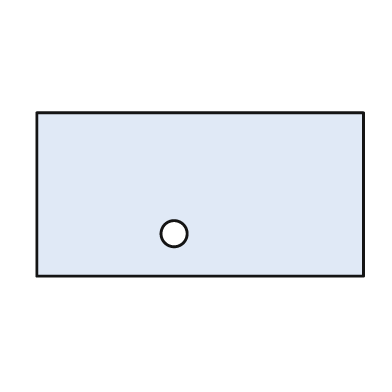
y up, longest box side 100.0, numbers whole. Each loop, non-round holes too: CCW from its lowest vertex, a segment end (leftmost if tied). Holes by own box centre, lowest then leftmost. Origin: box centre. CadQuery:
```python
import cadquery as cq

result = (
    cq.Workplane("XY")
    .moveTo(-50.0, -25.0)
    .lineTo(50.0, -25.0)
    .lineTo(50.0, 25.0)
    .lineTo(-50.0, 25.0)
    .close()
    .moveTo(-8.0, -12.0)
    .circle(4.0)
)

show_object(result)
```